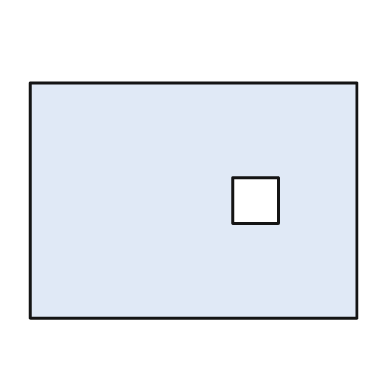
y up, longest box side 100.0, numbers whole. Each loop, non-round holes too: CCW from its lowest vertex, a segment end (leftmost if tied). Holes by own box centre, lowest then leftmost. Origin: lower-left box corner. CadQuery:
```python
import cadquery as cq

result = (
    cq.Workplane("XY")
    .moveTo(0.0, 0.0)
    .lineTo(100.0, 0.0)
    .lineTo(100.0, 72.0)
    .lineTo(0.0, 72.0)
    .close()
    .moveTo(62.0, 29.0)
    .lineTo(76.0, 29.0)
    .lineTo(76.0, 43.0)
    .lineTo(62.0, 43.0)
    .close()
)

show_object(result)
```